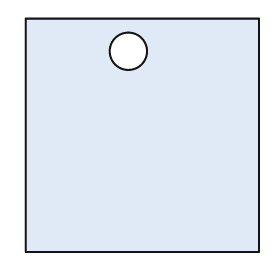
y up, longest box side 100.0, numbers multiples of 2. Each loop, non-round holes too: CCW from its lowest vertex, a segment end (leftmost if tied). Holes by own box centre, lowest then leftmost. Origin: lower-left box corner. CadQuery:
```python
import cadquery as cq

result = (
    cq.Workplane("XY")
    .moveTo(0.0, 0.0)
    .lineTo(100.0, 0.0)
    .lineTo(100.0, 100.0)
    .lineTo(0.0, 100.0)
    .close()
    .moveTo(44.0, 86.0)
    .circle(8.0)
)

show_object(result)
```